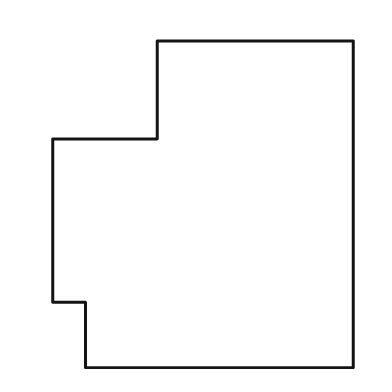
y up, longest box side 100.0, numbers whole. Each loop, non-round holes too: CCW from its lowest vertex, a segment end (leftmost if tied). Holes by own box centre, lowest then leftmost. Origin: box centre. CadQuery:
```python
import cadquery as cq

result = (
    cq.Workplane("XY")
    .moveTo(-36.0, -50.0)
    .lineTo(46.0, -50.0)
    .lineTo(46.0, 50.0)
    .lineTo(-14.0, 50.0)
    .lineTo(-14.0, 20.0)
    .lineTo(-46.0, 20.0)
    .lineTo(-46.0, -30.0)
    .lineTo(-36.0, -30.0)
    .close()
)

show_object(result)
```